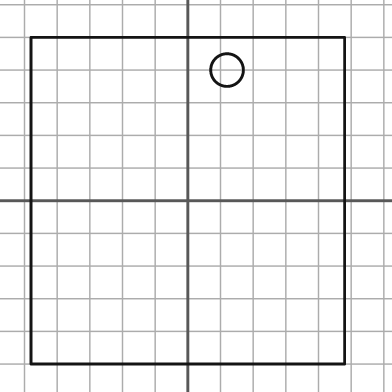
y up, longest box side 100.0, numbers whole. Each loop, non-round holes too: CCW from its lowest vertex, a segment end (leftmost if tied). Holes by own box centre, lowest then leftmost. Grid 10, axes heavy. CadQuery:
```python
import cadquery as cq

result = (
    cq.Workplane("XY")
    .moveTo(-48.0, -50.0)
    .lineTo(48.0, -50.0)
    .lineTo(48.0, 50.0)
    .lineTo(-48.0, 50.0)
    .close()
    .moveTo(12.0, 40.0)
    .circle(5.0)
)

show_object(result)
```